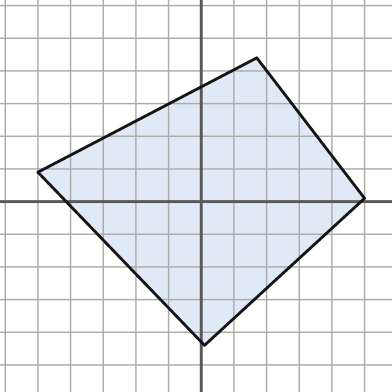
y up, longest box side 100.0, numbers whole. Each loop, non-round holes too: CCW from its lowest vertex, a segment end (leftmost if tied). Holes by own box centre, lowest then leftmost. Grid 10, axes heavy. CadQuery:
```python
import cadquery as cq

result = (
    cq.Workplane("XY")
    .moveTo(1.0, -44.0)
    .lineTo(50.0, 1.0)
    .lineTo(17.0, 44.0)
    .lineTo(-50.0, 9.0)
    .close()
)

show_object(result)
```